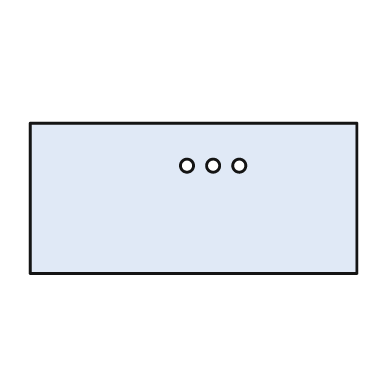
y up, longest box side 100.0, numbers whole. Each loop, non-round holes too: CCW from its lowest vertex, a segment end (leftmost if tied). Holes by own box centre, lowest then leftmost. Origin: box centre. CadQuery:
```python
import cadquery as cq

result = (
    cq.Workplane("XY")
    .moveTo(-50.0, -23.0)
    .lineTo(50.0, -23.0)
    .lineTo(50.0, 23.0)
    .lineTo(-50.0, 23.0)
    .close()
    .moveTo(-2.0, 10.0)
    .circle(2.0)
    .moveTo(6.0, 10.0)
    .circle(2.0)
    .moveTo(14.0, 10.0)
    .circle(2.0)
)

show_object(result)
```